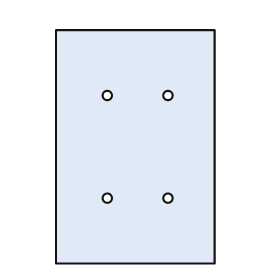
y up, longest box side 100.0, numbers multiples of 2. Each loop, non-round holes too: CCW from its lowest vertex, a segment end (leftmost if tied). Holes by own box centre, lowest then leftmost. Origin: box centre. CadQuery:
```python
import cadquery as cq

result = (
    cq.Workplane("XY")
    .moveTo(-34.0, -50.0)
    .lineTo(34.0, -50.0)
    .lineTo(34.0, 50.0)
    .lineTo(-34.0, 50.0)
    .close()
    .moveTo(-12.0, -22.0)
    .circle(2.0)
    .moveTo(14.0, -22.0)
    .circle(2.0)
    .moveTo(-12.0, 22.0)
    .circle(2.0)
    .moveTo(14.0, 22.0)
    .circle(2.0)
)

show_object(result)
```